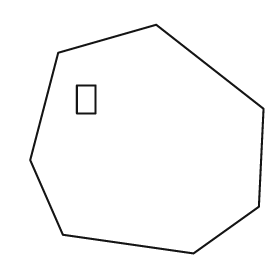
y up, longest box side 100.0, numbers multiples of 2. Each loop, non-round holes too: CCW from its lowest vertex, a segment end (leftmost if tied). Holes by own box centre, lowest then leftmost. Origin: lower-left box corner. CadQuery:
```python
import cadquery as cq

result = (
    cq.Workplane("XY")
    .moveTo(70.0, 0.0)
    .lineTo(98.0, 20.0)
    .lineTo(100.0, 62.0)
    .lineTo(54.0, 98.0)
    .lineTo(12.0, 86.0)
    .lineTo(0.0, 40.0)
    .lineTo(14.0, 8.0)
    .close()
    .moveTo(20.0, 60.0)
    .lineTo(28.0, 60.0)
    .lineTo(28.0, 72.0)
    .lineTo(20.0, 72.0)
    .close()
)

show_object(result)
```